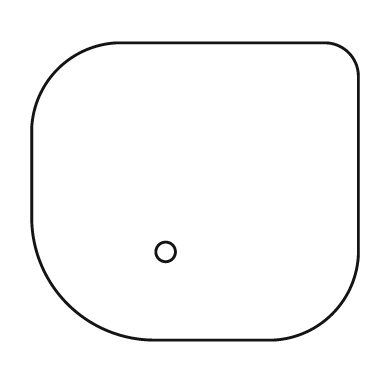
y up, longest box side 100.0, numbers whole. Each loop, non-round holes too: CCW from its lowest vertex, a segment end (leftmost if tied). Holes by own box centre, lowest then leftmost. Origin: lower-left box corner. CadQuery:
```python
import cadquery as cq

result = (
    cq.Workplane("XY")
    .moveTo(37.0, 0.0)
    .lineTo(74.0, 0.0)
    .threePointArc((92.0, 8.0), (100.0, 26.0))
    .lineTo(100.0, 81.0)
    .threePointArc((97.0, 88.0), (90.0, 91.0))
    .lineTo(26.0, 91.0)
    .threePointArc((8.0, 83.0), (0.0, 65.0))
    .lineTo(0.0, 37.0)
    .threePointArc((11.0, 11.0), (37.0, 0.0))
    .close()
    .moveTo(41.0, 27.0)
    .circle(3.0)
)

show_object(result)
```